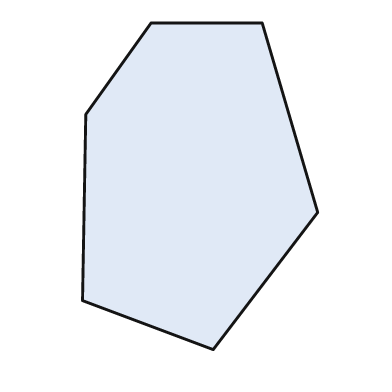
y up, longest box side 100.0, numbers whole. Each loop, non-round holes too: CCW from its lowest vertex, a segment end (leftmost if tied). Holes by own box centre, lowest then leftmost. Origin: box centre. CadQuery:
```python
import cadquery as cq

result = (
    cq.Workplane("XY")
    .moveTo(4.0, -50.0)
    .lineTo(36.0, -8.0)
    .lineTo(19.0, 50.0)
    .lineTo(-15.0, 50.0)
    .lineTo(-35.0, 22.0)
    .lineTo(-36.0, -35.0)
    .close()
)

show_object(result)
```